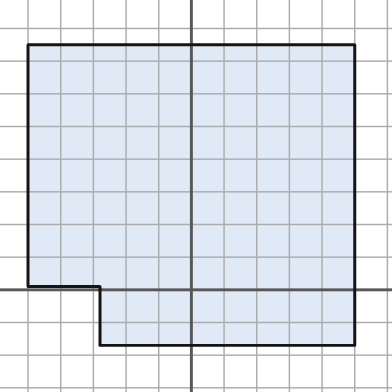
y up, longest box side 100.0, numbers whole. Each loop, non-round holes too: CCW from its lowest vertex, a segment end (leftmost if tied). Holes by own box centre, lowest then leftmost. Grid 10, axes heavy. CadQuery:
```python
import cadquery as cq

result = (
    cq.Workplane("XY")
    .moveTo(-28.0, -17.0)
    .lineTo(50.0, -17.0)
    .lineTo(50.0, 75.0)
    .lineTo(-50.0, 75.0)
    .lineTo(-50.0, 1.0)
    .lineTo(-28.0, 1.0)
    .close()
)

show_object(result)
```